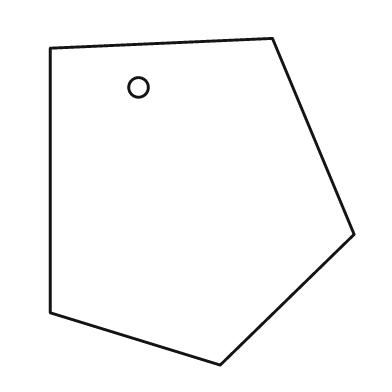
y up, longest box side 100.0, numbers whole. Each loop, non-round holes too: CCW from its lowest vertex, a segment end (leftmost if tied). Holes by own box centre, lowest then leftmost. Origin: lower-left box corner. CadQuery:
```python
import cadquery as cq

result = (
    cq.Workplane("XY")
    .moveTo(52.0, 0.0)
    .lineTo(93.0, 40.0)
    .lineTo(68.0, 100.0)
    .lineTo(0.0, 97.0)
    .lineTo(0.0, 16.0)
    .close()
    .moveTo(27.0, 85.0)
    .circle(3.0)
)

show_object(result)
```